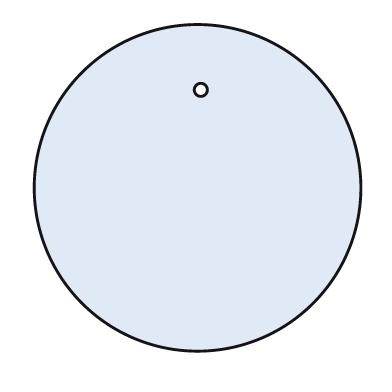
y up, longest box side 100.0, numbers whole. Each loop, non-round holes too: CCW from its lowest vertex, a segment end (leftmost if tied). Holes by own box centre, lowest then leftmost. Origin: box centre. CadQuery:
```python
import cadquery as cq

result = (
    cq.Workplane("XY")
    .moveTo(0.0, 0.0)
    .circle(50.0)
    .moveTo(1.0, 30.0)
    .circle(2.0)
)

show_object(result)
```